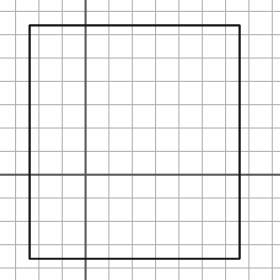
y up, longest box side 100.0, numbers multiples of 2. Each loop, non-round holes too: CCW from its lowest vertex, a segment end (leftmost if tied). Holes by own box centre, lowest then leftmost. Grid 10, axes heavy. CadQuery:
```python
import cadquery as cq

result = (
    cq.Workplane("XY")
    .moveTo(-24.0, -36.0)
    .lineTo(66.0, -36.0)
    .lineTo(66.0, 64.0)
    .lineTo(-24.0, 64.0)
    .close()
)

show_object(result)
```